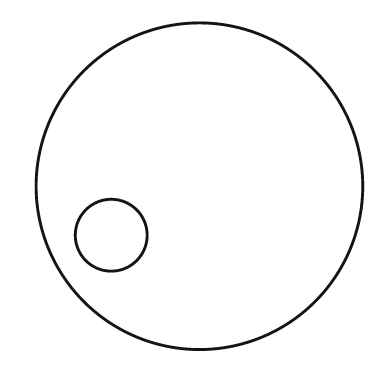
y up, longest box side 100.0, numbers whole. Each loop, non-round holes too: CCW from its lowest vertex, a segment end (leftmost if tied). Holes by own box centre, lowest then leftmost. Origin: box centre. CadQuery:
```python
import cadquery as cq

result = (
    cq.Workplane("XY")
    .moveTo(0.0, 0.0)
    .circle(50.0)
    .moveTo(-27.0, -15.0)
    .circle(11.0)
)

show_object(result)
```